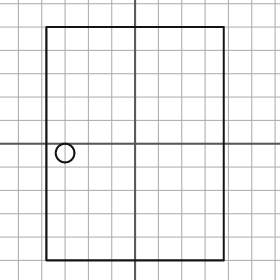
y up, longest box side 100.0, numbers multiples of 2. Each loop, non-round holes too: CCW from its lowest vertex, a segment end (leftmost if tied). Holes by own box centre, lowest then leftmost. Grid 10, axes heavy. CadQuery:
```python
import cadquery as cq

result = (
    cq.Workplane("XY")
    .moveTo(-38.0, -50.0)
    .lineTo(38.0, -50.0)
    .lineTo(38.0, 50.0)
    .lineTo(-38.0, 50.0)
    .close()
    .moveTo(-30.0, -4.0)
    .circle(4.0)
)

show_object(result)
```